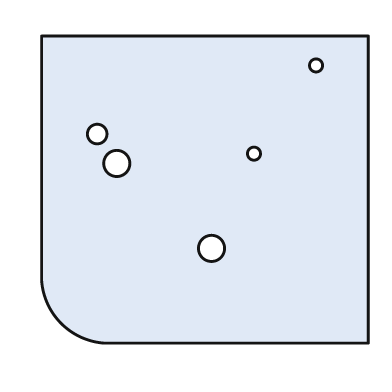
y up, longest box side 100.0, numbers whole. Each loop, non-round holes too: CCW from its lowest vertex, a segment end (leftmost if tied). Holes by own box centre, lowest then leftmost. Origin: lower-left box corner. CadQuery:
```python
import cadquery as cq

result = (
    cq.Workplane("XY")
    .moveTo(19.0, 0.0)
    .lineTo(100.0, 0.0)
    .lineTo(100.0, 94.0)
    .lineTo(0.0, 94.0)
    .lineTo(0.0, 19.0)
    .threePointArc((6.0, 6.0), (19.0, 0.0))
    .close()
    .moveTo(52.0, 29.0)
    .circle(4.0)
    .moveTo(23.0, 55.0)
    .circle(4.0)
    .moveTo(65.0, 58.0)
    .circle(2.0)
    .moveTo(17.0, 64.0)
    .circle(3.0)
    .moveTo(84.0, 85.0)
    .circle(2.0)
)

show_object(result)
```